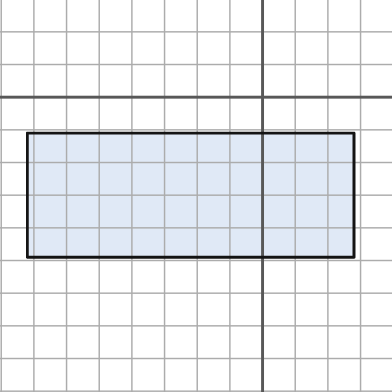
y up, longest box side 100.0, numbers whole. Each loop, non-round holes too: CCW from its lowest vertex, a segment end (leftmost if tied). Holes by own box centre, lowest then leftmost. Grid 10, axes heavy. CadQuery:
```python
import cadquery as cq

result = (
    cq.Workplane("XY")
    .moveTo(-72.0, -49.0)
    .lineTo(28.0, -49.0)
    .lineTo(28.0, -11.0)
    .lineTo(-72.0, -11.0)
    .close()
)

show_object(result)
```